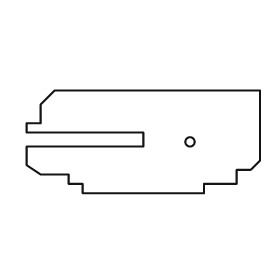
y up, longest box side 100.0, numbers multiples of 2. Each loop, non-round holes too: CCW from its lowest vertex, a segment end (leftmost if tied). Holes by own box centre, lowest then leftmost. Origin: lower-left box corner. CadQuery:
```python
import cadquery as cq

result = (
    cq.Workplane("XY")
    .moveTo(24.0, 0.0)
    .lineTo(76.0, 0.0)
    .lineTo(76.0, 4.0)
    .lineTo(90.0, 4.0)
    .lineTo(90.0, 10.0)
    .lineTo(96.0, 10.0)
    .lineTo(100.0, 14.0)
    .lineTo(100.0, 44.0)
    .lineTo(12.0, 44.0)
    .lineTo(6.0, 38.0)
    .lineTo(6.0, 30.0)
    .lineTo(0.0, 30.0)
    .lineTo(0.0, 26.0)
    .lineTo(50.0, 26.0)
    .lineTo(50.0, 20.0)
    .lineTo(0.0, 20.0)
    .lineTo(0.0, 12.0)
    .lineTo(6.0, 8.0)
    .lineTo(18.0, 8.0)
    .lineTo(18.0, 4.0)
    .lineTo(24.0, 4.0)
    .close()
    .moveTo(70.0, 22.0)
    .circle(2.0)
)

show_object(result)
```